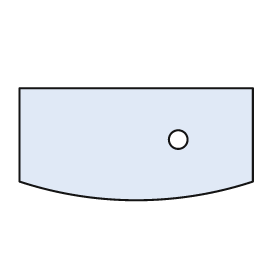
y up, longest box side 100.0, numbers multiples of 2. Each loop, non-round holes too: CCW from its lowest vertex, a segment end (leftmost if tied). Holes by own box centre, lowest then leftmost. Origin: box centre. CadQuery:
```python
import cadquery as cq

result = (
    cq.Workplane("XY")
    .moveTo(-50.0, -16.0)
    .threePointArc((0.0, -24.0), (50.0, -16.0))
    .lineTo(50.0, 24.0)
    .lineTo(-50.0, 24.0)
    .close()
    .moveTo(18.0, 2.0)
    .circle(4.0)
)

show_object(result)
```